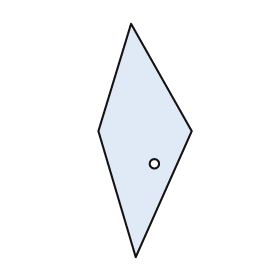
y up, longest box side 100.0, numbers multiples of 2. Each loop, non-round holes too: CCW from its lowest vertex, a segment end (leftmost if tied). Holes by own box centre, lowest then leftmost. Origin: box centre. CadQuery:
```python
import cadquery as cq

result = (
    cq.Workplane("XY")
    .moveTo(-4.0, -50.0)
    .lineTo(20.0, 4.0)
    .lineTo(-6.0, 50.0)
    .lineTo(-20.0, 4.0)
    .close()
    .moveTo(4.0, -10.0)
    .circle(2.0)
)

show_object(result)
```